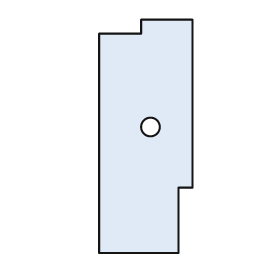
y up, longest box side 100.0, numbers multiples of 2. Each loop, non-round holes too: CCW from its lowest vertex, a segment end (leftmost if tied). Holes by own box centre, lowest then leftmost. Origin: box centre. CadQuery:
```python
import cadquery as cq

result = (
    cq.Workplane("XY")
    .moveTo(-20.0, -50.0)
    .lineTo(14.0, -50.0)
    .lineTo(14.0, -22.0)
    .lineTo(20.0, -22.0)
    .lineTo(20.0, 50.0)
    .lineTo(-2.0, 50.0)
    .lineTo(-2.0, 44.0)
    .lineTo(-20.0, 44.0)
    .close()
    .moveTo(2.0, 4.0)
    .circle(4.0)
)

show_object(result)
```